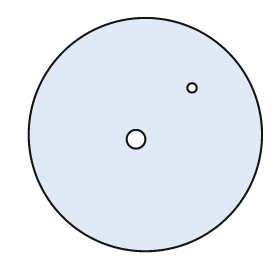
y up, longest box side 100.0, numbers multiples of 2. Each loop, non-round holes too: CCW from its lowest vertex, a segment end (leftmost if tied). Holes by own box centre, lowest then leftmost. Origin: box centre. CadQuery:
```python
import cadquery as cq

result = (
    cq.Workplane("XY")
    .moveTo(0.0, 0.0)
    .circle(50.0)
    .moveTo(-4.0, -2.0)
    .circle(4.0)
    .moveTo(20.0, 20.0)
    .circle(2.0)
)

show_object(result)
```